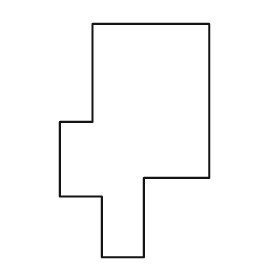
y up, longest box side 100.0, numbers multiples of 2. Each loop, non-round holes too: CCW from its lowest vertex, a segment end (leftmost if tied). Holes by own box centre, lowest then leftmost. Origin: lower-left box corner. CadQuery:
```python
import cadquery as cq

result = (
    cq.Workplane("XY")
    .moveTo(18.0, 0.0)
    .lineTo(36.0, 0.0)
    .lineTo(36.0, 34.0)
    .lineTo(64.0, 34.0)
    .lineTo(64.0, 100.0)
    .lineTo(14.0, 100.0)
    .lineTo(14.0, 58.0)
    .lineTo(0.0, 58.0)
    .lineTo(0.0, 26.0)
    .lineTo(18.0, 26.0)
    .close()
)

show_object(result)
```